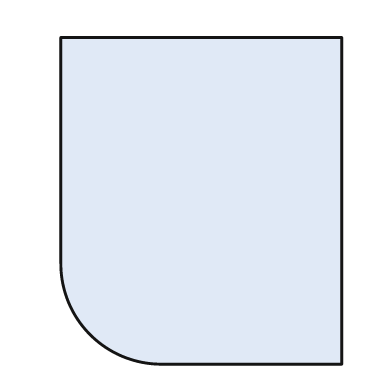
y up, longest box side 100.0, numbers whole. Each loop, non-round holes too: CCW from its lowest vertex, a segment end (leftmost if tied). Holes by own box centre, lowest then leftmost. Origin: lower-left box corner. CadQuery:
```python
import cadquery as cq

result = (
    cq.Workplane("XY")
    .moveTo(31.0, 0.0)
    .lineTo(86.0, 0.0)
    .lineTo(86.0, 100.0)
    .lineTo(0.0, 100.0)
    .lineTo(0.0, 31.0)
    .threePointArc((9.0, 9.0), (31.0, 0.0))
    .close()
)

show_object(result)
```